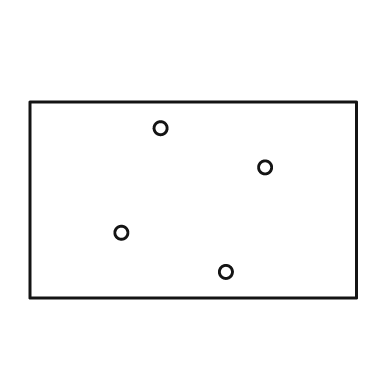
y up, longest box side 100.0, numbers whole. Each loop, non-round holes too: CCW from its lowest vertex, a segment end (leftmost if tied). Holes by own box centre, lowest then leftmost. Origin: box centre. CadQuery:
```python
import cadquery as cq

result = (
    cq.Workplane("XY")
    .moveTo(-50.0, -30.0)
    .lineTo(50.0, -30.0)
    .lineTo(50.0, 30.0)
    .lineTo(-50.0, 30.0)
    .close()
    .moveTo(10.0, -22.0)
    .circle(2.0)
    .moveTo(-22.0, -10.0)
    .circle(2.0)
    .moveTo(22.0, 10.0)
    .circle(2.0)
    .moveTo(-10.0, 22.0)
    .circle(2.0)
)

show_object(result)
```